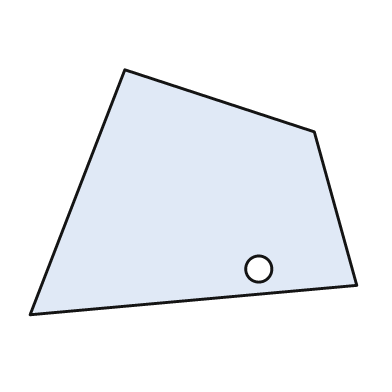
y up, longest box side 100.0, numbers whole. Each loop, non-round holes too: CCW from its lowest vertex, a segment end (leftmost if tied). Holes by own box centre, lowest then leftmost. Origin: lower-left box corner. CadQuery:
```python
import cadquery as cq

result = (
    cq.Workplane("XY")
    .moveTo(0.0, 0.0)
    .lineTo(100.0, 9.0)
    .lineTo(87.0, 56.0)
    .lineTo(29.0, 75.0)
    .close()
    .moveTo(70.0, 14.0)
    .circle(4.0)
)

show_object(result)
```